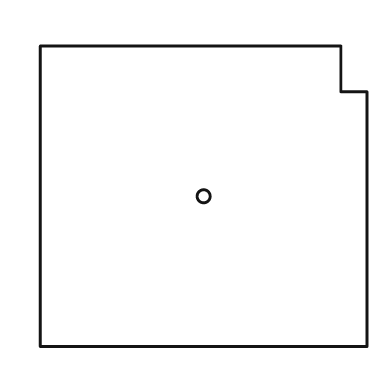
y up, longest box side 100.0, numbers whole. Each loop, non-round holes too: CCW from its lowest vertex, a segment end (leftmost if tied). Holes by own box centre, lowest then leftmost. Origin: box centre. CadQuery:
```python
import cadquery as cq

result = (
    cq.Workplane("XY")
    .moveTo(-50.0, -46.0)
    .lineTo(50.0, -46.0)
    .lineTo(50.0, 32.0)
    .lineTo(42.0, 32.0)
    .lineTo(42.0, 46.0)
    .lineTo(-50.0, 46.0)
    .close()
    .moveTo(0.0, 0.0)
    .circle(2.0)
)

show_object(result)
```